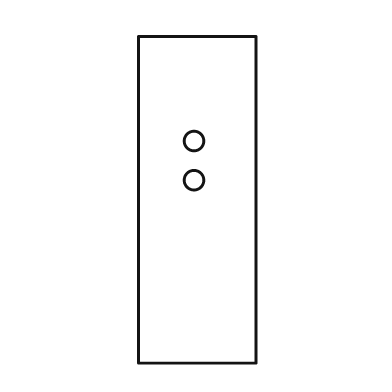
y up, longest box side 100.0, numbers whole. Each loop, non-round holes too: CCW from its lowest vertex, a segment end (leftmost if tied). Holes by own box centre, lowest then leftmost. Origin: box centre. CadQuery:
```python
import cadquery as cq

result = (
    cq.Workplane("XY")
    .moveTo(-18.0, -50.0)
    .lineTo(18.0, -50.0)
    .lineTo(18.0, 50.0)
    .lineTo(-18.0, 50.0)
    .close()
    .moveTo(-1.0, 6.0)
    .circle(3.0)
    .moveTo(-1.0, 18.0)
    .circle(3.0)
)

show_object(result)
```